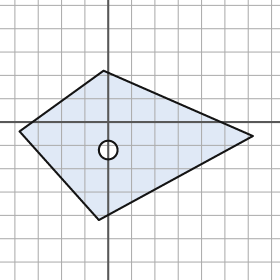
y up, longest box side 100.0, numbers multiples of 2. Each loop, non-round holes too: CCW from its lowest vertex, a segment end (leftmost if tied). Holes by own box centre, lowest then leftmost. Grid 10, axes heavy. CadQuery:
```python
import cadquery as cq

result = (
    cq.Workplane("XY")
    .moveTo(-4.0, -42.0)
    .lineTo(62.0, -6.0)
    .lineTo(-2.0, 22.0)
    .lineTo(-38.0, -4.0)
    .close()
    .moveTo(0.0, -12.0)
    .circle(4.0)
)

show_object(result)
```